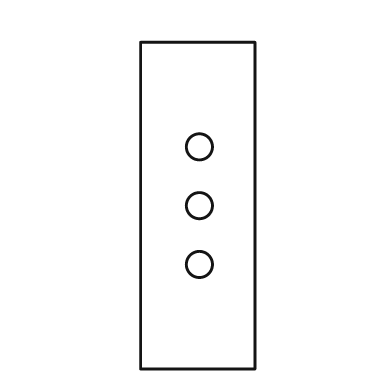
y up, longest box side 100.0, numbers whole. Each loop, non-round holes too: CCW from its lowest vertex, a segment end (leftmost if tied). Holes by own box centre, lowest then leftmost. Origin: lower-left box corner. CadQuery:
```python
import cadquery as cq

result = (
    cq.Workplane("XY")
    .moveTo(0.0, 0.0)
    .lineTo(35.0, 0.0)
    .lineTo(35.0, 100.0)
    .lineTo(0.0, 100.0)
    .close()
    .moveTo(18.0, 32.0)
    .circle(4.0)
    .moveTo(18.0, 50.0)
    .circle(4.0)
    .moveTo(18.0, 68.0)
    .circle(4.0)
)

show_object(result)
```